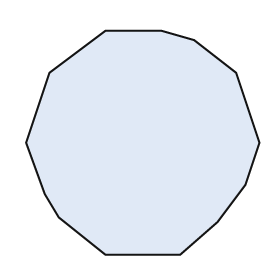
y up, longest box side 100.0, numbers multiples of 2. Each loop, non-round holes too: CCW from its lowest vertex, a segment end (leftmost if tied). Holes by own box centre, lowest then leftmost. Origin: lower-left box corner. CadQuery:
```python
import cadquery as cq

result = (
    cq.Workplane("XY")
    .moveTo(34.0, 0.0)
    .lineTo(66.0, 0.0)
    .lineTo(82.0, 14.0)
    .lineTo(94.0, 30.0)
    .lineTo(100.0, 48.0)
    .lineTo(90.0, 78.0)
    .lineTo(72.0, 92.0)
    .lineTo(58.0, 96.0)
    .lineTo(34.0, 96.0)
    .lineTo(10.0, 78.0)
    .lineTo(0.0, 48.0)
    .lineTo(8.0, 26.0)
    .lineTo(14.0, 16.0)
    .close()
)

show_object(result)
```